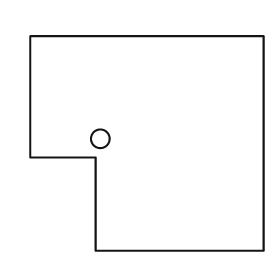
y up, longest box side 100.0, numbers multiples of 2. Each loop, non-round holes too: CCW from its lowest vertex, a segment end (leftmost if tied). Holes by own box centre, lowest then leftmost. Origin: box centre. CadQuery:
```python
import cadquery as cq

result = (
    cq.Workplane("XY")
    .moveTo(-22.0, -46.0)
    .lineTo(50.0, -46.0)
    .lineTo(50.0, 46.0)
    .lineTo(-50.0, 46.0)
    .lineTo(-50.0, -6.0)
    .lineTo(-22.0, -6.0)
    .close()
    .moveTo(-20.0, 2.0)
    .circle(4.0)
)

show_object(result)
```